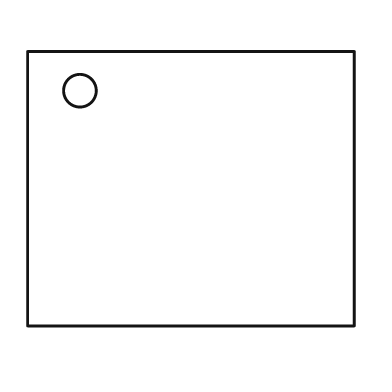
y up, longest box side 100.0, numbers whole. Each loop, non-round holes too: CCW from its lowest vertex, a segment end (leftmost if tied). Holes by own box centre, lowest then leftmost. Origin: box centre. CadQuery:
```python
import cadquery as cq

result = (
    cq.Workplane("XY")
    .moveTo(-50.0, -42.0)
    .lineTo(50.0, -42.0)
    .lineTo(50.0, 42.0)
    .lineTo(-50.0, 42.0)
    .close()
    .moveTo(-34.0, 30.0)
    .circle(5.0)
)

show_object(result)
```